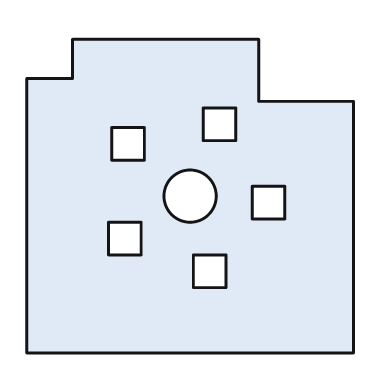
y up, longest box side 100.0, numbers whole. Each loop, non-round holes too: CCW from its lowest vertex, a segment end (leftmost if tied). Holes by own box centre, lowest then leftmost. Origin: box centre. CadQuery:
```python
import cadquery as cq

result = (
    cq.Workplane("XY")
    .moveTo(-50.0, -48.0)
    .lineTo(50.0, -48.0)
    .lineTo(50.0, 29.0)
    .lineTo(21.0, 29.0)
    .lineTo(21.0, 48.0)
    .lineTo(-36.0, 48.0)
    .lineTo(-36.0, 36.0)
    .lineTo(-50.0, 36.0)
    .close()
    .moveTo(1.0, -28.0)
    .lineTo(11.0, -28.0)
    .lineTo(11.0, -18.0)
    .lineTo(1.0, -18.0)
    .close()
    .moveTo(-25.0, -18.0)
    .lineTo(-15.0, -18.0)
    .lineTo(-15.0, -8.0)
    .lineTo(-25.0, -8.0)
    .close()
    .moveTo(19.0, -7.0)
    .lineTo(29.0, -7.0)
    .lineTo(29.0, 3.0)
    .lineTo(19.0, 3.0)
    .close()
    .moveTo(0.0, 0.0)
    .circle(8.0)
    .moveTo(-24.0, 11.0)
    .lineTo(-14.0, 11.0)
    .lineTo(-14.0, 21.0)
    .lineTo(-24.0, 21.0)
    .close()
    .moveTo(4.0, 17.0)
    .lineTo(14.0, 17.0)
    .lineTo(14.0, 27.0)
    .lineTo(4.0, 27.0)
    .close()
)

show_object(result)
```